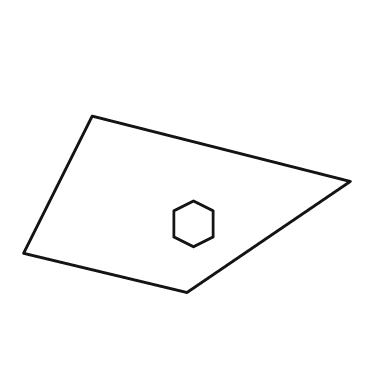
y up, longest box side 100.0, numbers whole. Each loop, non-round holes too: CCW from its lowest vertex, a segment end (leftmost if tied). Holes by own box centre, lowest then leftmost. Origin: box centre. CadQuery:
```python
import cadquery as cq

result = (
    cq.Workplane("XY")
    .moveTo(0.0, -27.0)
    .lineTo(50.0, 7.0)
    .lineTo(-29.0, 27.0)
    .lineTo(-50.0, -15.0)
    .close()
    .moveTo(2.0, -13.0)
    .lineTo(8.0, -10.0)
    .lineTo(8.0, -2.0)
    .lineTo(2.0, 1.0)
    .lineTo(-4.0, -2.0)
    .lineTo(-4.0, -10.0)
    .close()
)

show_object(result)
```